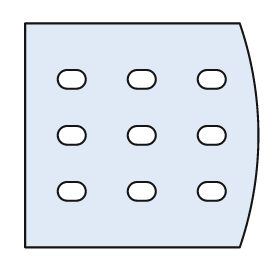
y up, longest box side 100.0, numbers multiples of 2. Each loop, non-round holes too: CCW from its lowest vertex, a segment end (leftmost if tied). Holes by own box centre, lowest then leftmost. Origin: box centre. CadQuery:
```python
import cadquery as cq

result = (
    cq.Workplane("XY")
    .moveTo(-50.0, -48.0)
    .lineTo(42.0, -48.0)
    .threePointArc((50.0, 0.0), (42.0, 48.0))
    .lineTo(-50.0, 48.0)
    .close()
    .moveTo(-32.0, -28.0)
    .lineTo(-28.0, -28.0)
    .threePointArc((-24.0, -24.0), (-28.0, -20.0))
    .lineTo(-32.0, -20.0)
    .threePointArc((-36.0, -24.0), (-32.0, -28.0))
    .close()
    .moveTo(-2.0, -28.0)
    .lineTo(2.0, -28.0)
    .threePointArc((6.0, -24.0), (2.0, -20.0))
    .lineTo(-2.0, -20.0)
    .threePointArc((-6.0, -24.0), (-2.0, -28.0))
    .close()
    .moveTo(28.0, -28.0)
    .lineTo(32.0, -28.0)
    .threePointArc((36.0, -24.0), (32.0, -20.0))
    .lineTo(28.0, -20.0)
    .threePointArc((24.0, -24.0), (28.0, -28.0))
    .close()
    .moveTo(-32.0, -4.0)
    .lineTo(-28.0, -4.0)
    .threePointArc((-24.0, 0.0), (-28.0, 4.0))
    .lineTo(-32.0, 4.0)
    .threePointArc((-36.0, 0.0), (-32.0, -4.0))
    .close()
    .moveTo(-2.0, -4.0)
    .lineTo(2.0, -4.0)
    .threePointArc((6.0, 0.0), (2.0, 4.0))
    .lineTo(-2.0, 4.0)
    .threePointArc((-6.0, 0.0), (-2.0, -4.0))
    .close()
    .moveTo(28.0, -4.0)
    .lineTo(32.0, -4.0)
    .threePointArc((36.0, 0.0), (32.0, 4.0))
    .lineTo(28.0, 4.0)
    .threePointArc((24.0, 0.0), (28.0, -4.0))
    .close()
    .moveTo(-32.0, 20.0)
    .lineTo(-28.0, 20.0)
    .threePointArc((-24.0, 24.0), (-28.0, 28.0))
    .lineTo(-32.0, 28.0)
    .threePointArc((-36.0, 24.0), (-32.0, 20.0))
    .close()
    .moveTo(-2.0, 20.0)
    .lineTo(2.0, 20.0)
    .threePointArc((6.0, 24.0), (2.0, 28.0))
    .lineTo(-2.0, 28.0)
    .threePointArc((-6.0, 24.0), (-2.0, 20.0))
    .close()
    .moveTo(28.0, 20.0)
    .lineTo(32.0, 20.0)
    .threePointArc((36.0, 24.0), (32.0, 28.0))
    .lineTo(28.0, 28.0)
    .threePointArc((24.0, 24.0), (28.0, 20.0))
    .close()
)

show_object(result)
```